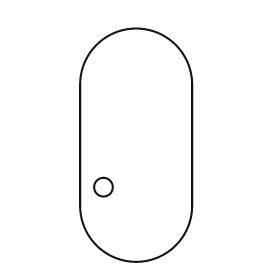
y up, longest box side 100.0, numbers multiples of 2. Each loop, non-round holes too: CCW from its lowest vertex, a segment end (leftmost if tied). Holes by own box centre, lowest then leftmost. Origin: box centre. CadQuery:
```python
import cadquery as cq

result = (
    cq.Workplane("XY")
    .moveTo(-24.0, -26.0)
    .threePointArc((0.0, -50.0), (24.0, -26.0))
    .lineTo(24.0, 26.0)
    .threePointArc((0.0, 50.0), (-24.0, 26.0))
    .close()
    .moveTo(-14.0, -18.0)
    .circle(4.0)
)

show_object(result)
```